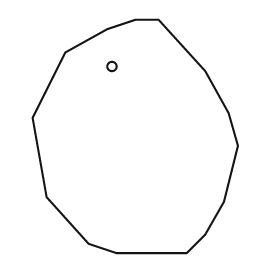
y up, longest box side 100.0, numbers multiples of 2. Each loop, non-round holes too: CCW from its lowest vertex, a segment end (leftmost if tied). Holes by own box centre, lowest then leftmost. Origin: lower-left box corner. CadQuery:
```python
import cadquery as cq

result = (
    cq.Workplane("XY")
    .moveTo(36.0, 0.0)
    .lineTo(66.0, 0.0)
    .lineTo(74.0, 8.0)
    .lineTo(82.0, 22.0)
    .lineTo(88.0, 46.0)
    .lineTo(84.0, 60.0)
    .lineTo(74.0, 78.0)
    .lineTo(54.0, 100.0)
    .lineTo(44.0, 100.0)
    .lineTo(32.0, 96.0)
    .lineTo(14.0, 86.0)
    .lineTo(0.0, 58.0)
    .lineTo(6.0, 24.0)
    .lineTo(24.0, 4.0)
    .close()
    .moveTo(34.0, 80.0)
    .circle(2.0)
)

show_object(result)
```